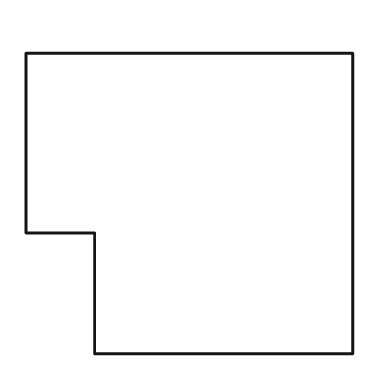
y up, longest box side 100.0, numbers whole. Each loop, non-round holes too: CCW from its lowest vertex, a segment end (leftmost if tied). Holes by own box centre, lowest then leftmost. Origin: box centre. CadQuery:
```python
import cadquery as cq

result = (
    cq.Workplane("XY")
    .moveTo(-29.0, -46.0)
    .lineTo(50.0, -46.0)
    .lineTo(50.0, 46.0)
    .lineTo(-50.0, 46.0)
    .lineTo(-50.0, -9.0)
    .lineTo(-29.0, -9.0)
    .close()
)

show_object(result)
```